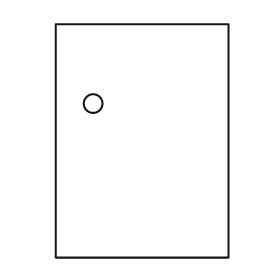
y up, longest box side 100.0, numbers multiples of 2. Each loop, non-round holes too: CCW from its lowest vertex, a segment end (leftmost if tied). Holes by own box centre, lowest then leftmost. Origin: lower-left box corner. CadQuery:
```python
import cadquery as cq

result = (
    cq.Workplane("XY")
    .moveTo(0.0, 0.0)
    .lineTo(74.0, 0.0)
    .lineTo(74.0, 100.0)
    .lineTo(0.0, 100.0)
    .close()
    .moveTo(16.0, 66.0)
    .circle(4.0)
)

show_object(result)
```